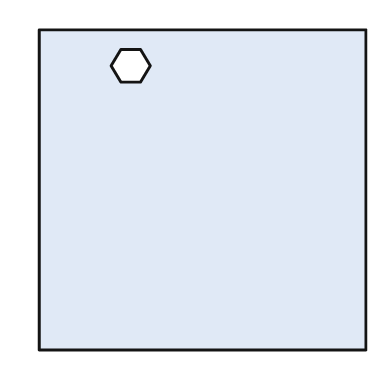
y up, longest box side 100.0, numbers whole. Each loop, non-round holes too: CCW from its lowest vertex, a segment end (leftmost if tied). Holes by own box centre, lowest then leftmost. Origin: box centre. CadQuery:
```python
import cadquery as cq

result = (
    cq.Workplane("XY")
    .moveTo(-50.0, -49.0)
    .lineTo(50.0, -49.0)
    .lineTo(50.0, 49.0)
    .lineTo(-50.0, 49.0)
    .close()
    .moveTo(-25.0, 33.0)
    .lineTo(-19.0, 33.0)
    .lineTo(-16.0, 38.0)
    .lineTo(-19.0, 43.0)
    .lineTo(-25.0, 43.0)
    .lineTo(-28.0, 38.0)
    .close()
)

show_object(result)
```